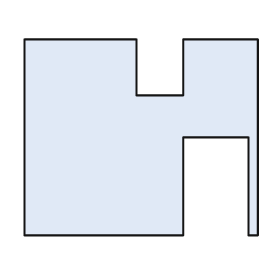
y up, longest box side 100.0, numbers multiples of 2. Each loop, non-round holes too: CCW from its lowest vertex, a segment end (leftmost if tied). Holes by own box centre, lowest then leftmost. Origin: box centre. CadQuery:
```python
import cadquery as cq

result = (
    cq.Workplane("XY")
    .moveTo(-50.0, -42.0)
    .lineTo(18.0, -42.0)
    .lineTo(18.0, 0.0)
    .lineTo(46.0, 0.0)
    .lineTo(46.0, -42.0)
    .lineTo(50.0, -42.0)
    .lineTo(50.0, 42.0)
    .lineTo(18.0, 42.0)
    .lineTo(18.0, 18.0)
    .lineTo(-2.0, 18.0)
    .lineTo(-2.0, 42.0)
    .lineTo(-50.0, 42.0)
    .close()
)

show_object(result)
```